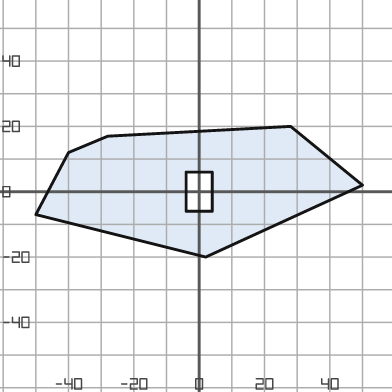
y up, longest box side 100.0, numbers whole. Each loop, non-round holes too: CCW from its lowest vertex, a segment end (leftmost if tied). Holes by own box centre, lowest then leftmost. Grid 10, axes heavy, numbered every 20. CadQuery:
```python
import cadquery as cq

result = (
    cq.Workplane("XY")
    .moveTo(2.0, -20.0)
    .lineTo(50.0, 2.0)
    .lineTo(28.0, 20.0)
    .lineTo(-28.0, 17.0)
    .lineTo(-40.0, 12.0)
    .lineTo(-50.0, -7.0)
    .close()
    .moveTo(-4.0, -6.0)
    .lineTo(4.0, -6.0)
    .lineTo(4.0, 6.0)
    .lineTo(-4.0, 6.0)
    .close()
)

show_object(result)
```